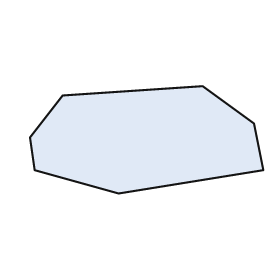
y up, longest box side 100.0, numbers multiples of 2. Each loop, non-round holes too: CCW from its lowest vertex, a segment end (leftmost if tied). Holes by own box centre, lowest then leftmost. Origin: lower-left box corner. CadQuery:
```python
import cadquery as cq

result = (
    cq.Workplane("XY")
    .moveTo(38.0, 0.0)
    .lineTo(100.0, 10.0)
    .lineTo(96.0, 30.0)
    .lineTo(74.0, 46.0)
    .lineTo(14.0, 42.0)
    .lineTo(0.0, 24.0)
    .lineTo(2.0, 10.0)
    .close()
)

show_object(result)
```